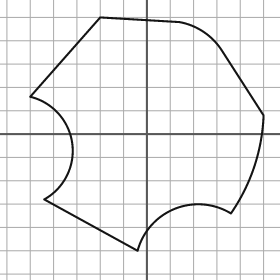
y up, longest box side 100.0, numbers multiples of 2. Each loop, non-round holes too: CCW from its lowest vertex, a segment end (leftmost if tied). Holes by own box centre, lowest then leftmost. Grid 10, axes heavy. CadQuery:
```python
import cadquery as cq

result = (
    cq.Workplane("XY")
    .moveTo(-4.0, -50.0)
    .threePointArc((12.0, -32.0), (36.0, -34.0))
    .threePointArc((46.0, -14.0), (50.0, 8.0))
    .lineTo(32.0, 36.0)
    .threePointArc((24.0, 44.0), (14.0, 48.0))
    .lineTo(-20.0, 50.0)
    .lineTo(-50.0, 16.0)
    .threePointArc((-32.0, -4.0), (-44.0, -28.0))
    .close()
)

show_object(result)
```